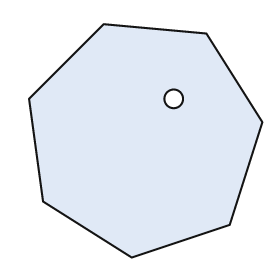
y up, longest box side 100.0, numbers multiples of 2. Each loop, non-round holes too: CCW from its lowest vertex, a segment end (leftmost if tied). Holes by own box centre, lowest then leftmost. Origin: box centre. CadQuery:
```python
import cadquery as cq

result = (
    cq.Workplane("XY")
    .moveTo(-6.0, -50.0)
    .lineTo(36.0, -36.0)
    .lineTo(50.0, 8.0)
    .lineTo(26.0, 46.0)
    .lineTo(-18.0, 50.0)
    .lineTo(-50.0, 18.0)
    .lineTo(-44.0, -26.0)
    .close()
    .moveTo(12.0, 18.0)
    .circle(4.0)
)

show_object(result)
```